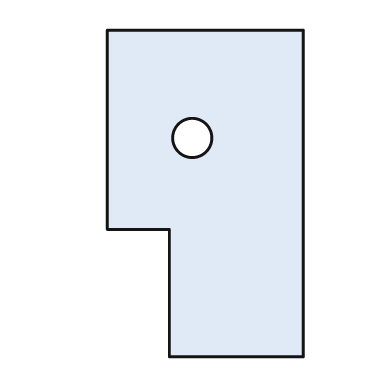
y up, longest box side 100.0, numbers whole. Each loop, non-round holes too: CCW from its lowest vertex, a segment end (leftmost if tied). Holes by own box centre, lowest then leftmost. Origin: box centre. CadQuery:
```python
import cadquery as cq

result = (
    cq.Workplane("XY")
    .moveTo(-11.0, -50.0)
    .lineTo(30.0, -50.0)
    .lineTo(30.0, 50.0)
    .lineTo(-30.0, 50.0)
    .lineTo(-30.0, -11.0)
    .lineTo(-11.0, -11.0)
    .close()
    .moveTo(-4.0, 17.0)
    .circle(6.0)
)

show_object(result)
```